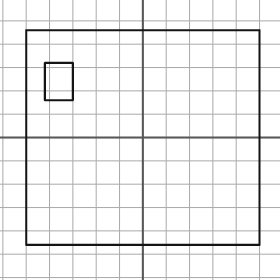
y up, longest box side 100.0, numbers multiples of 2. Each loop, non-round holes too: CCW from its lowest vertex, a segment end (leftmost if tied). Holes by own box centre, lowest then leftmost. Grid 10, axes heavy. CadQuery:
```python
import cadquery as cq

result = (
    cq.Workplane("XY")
    .moveTo(-50.0, -46.0)
    .lineTo(50.0, -46.0)
    .lineTo(50.0, 46.0)
    .lineTo(-50.0, 46.0)
    .close()
    .moveTo(-42.0, 16.0)
    .lineTo(-30.0, 16.0)
    .lineTo(-30.0, 32.0)
    .lineTo(-42.0, 32.0)
    .close()
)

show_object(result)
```